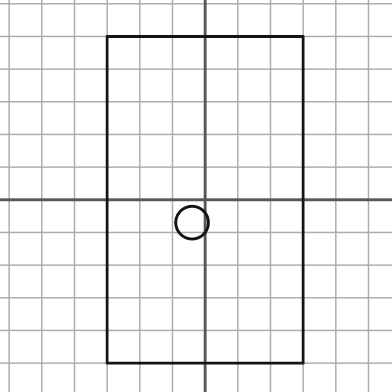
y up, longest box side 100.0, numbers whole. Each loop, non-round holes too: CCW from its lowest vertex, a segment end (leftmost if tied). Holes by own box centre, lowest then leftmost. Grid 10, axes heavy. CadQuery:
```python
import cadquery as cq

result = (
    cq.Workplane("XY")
    .moveTo(-30.0, -50.0)
    .lineTo(30.0, -50.0)
    .lineTo(30.0, 50.0)
    .lineTo(-30.0, 50.0)
    .close()
    .moveTo(-4.0, -7.0)
    .circle(5.0)
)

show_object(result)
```